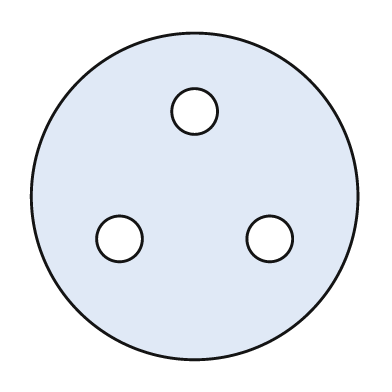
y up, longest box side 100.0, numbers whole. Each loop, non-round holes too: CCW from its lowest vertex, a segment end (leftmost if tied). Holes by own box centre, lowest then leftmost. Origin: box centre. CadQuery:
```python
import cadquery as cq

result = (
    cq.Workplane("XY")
    .moveTo(0.0, 0.0)
    .circle(50.0)
    .moveTo(-23.0, -13.0)
    .circle(7.0)
    .moveTo(23.0, -13.0)
    .circle(7.0)
    .moveTo(0.0, 26.0)
    .circle(7.0)
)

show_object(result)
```